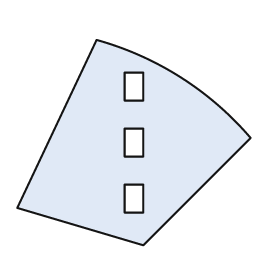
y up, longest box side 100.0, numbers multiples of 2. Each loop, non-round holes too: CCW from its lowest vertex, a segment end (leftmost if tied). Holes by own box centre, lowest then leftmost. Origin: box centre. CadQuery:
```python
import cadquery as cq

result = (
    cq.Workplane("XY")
    .moveTo(4.0, -44.0)
    .lineTo(50.0, 2.0)
    .threePointArc((20.0, 28.0), (-16.0, 44.0))
    .lineTo(-50.0, -28.0)
    .close()
    .moveTo(-4.0, -30.0)
    .lineTo(4.0, -30.0)
    .lineTo(4.0, -18.0)
    .lineTo(-4.0, -18.0)
    .close()
    .moveTo(-4.0, -6.0)
    .lineTo(4.0, -6.0)
    .lineTo(4.0, 6.0)
    .lineTo(-4.0, 6.0)
    .close()
    .moveTo(-4.0, 18.0)
    .lineTo(4.0, 18.0)
    .lineTo(4.0, 30.0)
    .lineTo(-4.0, 30.0)
    .close()
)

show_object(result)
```